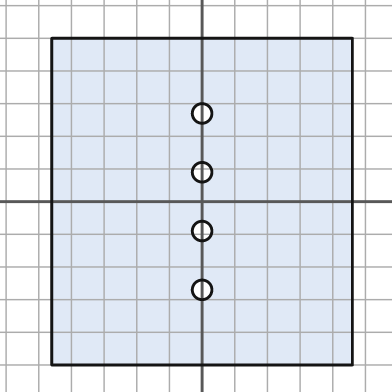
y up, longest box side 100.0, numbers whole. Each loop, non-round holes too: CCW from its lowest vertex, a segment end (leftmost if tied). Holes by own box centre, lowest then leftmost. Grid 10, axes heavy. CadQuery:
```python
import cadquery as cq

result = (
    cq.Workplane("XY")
    .moveTo(-46.0, -50.0)
    .lineTo(46.0, -50.0)
    .lineTo(46.0, 50.0)
    .lineTo(-46.0, 50.0)
    .close()
    .moveTo(0.0, -27.0)
    .circle(3.0)
    .moveTo(0.0, -9.0)
    .circle(3.0)
    .moveTo(0.0, 9.0)
    .circle(3.0)
    .moveTo(0.0, 27.0)
    .circle(3.0)
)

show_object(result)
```